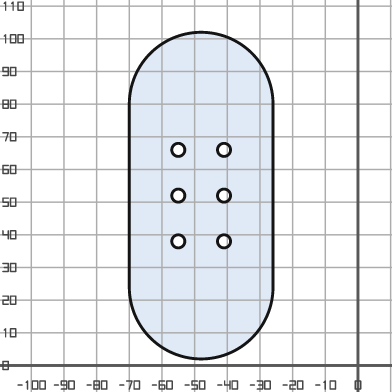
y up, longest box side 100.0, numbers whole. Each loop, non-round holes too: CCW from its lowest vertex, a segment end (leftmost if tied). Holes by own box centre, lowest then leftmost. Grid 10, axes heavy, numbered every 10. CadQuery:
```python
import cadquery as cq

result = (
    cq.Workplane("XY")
    .moveTo(-70.0, 24.0)
    .threePointArc((-48.0, 2.0), (-26.0, 24.0))
    .lineTo(-26.0, 80.0)
    .threePointArc((-48.0, 102.0), (-70.0, 80.0))
    .close()
    .moveTo(-55.0, 38.0)
    .circle(2.0)
    .moveTo(-41.0, 38.0)
    .circle(2.0)
    .moveTo(-55.0, 52.0)
    .circle(2.0)
    .moveTo(-41.0, 52.0)
    .circle(2.0)
    .moveTo(-55.0, 66.0)
    .circle(2.0)
    .moveTo(-41.0, 66.0)
    .circle(2.0)
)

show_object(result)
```